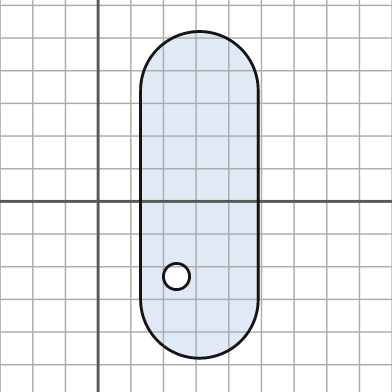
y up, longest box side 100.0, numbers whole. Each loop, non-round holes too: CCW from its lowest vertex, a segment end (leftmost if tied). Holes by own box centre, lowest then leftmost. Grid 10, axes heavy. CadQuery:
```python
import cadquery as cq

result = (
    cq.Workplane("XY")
    .moveTo(13.0, -30.0)
    .threePointArc((31.0, -48.0), (49.0, -30.0))
    .lineTo(49.0, 34.0)
    .threePointArc((31.0, 52.0), (13.0, 34.0))
    .close()
    .moveTo(24.0, -23.0)
    .circle(4.0)
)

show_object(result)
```